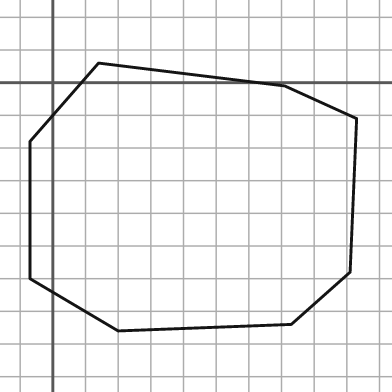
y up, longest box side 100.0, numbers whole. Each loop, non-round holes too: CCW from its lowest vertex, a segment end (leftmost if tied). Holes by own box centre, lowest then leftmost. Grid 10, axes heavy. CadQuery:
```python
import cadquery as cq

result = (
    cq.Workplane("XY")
    .moveTo(20.0, -76.0)
    .lineTo(73.0, -74.0)
    .lineTo(91.0, -58.0)
    .lineTo(93.0, -11.0)
    .lineTo(71.0, -1.0)
    .lineTo(14.0, 6.0)
    .lineTo(-7.0, -18.0)
    .lineTo(-7.0, -60.0)
    .close()
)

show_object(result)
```